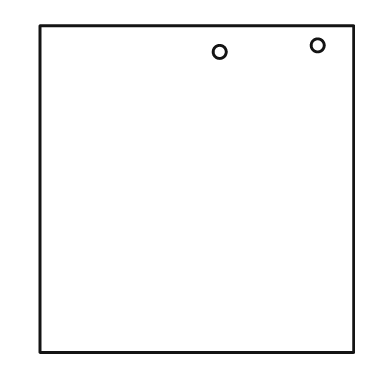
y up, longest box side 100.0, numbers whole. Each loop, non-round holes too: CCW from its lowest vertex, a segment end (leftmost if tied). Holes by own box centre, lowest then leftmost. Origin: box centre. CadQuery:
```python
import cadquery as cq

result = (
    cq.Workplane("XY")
    .moveTo(-48.0, -50.0)
    .lineTo(48.0, -50.0)
    .lineTo(48.0, 50.0)
    .lineTo(-48.0, 50.0)
    .close()
    .moveTo(7.0, 42.0)
    .circle(2.0)
    .moveTo(37.0, 44.0)
    .circle(2.0)
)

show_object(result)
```